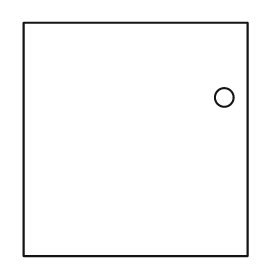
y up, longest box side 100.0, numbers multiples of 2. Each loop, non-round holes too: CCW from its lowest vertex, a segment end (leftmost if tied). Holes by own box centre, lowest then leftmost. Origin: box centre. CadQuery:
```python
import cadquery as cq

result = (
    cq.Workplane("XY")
    .moveTo(-48.0, -50.0)
    .lineTo(48.0, -50.0)
    .lineTo(48.0, 50.0)
    .lineTo(-48.0, 50.0)
    .close()
    .moveTo(38.0, 18.0)
    .circle(4.0)
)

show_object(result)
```